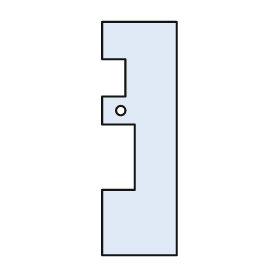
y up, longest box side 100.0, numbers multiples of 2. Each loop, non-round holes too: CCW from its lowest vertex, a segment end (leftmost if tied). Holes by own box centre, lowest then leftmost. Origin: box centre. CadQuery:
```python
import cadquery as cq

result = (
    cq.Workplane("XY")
    .moveTo(-16.0, -50.0)
    .lineTo(16.0, -50.0)
    .lineTo(16.0, 50.0)
    .lineTo(-16.0, 50.0)
    .lineTo(-16.0, 34.0)
    .lineTo(-6.0, 34.0)
    .lineTo(-6.0, 18.0)
    .lineTo(-16.0, 18.0)
    .lineTo(-16.0, 6.0)
    .lineTo(-2.0, 6.0)
    .lineTo(-2.0, -22.0)
    .lineTo(-16.0, -22.0)
    .close()
    .moveTo(-8.0, 12.0)
    .circle(2.0)
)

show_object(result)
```